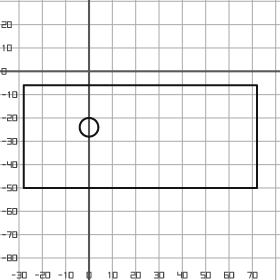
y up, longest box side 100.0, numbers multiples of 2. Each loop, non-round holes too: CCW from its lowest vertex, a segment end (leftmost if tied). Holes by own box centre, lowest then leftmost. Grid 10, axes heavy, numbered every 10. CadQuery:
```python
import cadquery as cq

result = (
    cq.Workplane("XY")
    .moveTo(-28.0, -50.0)
    .lineTo(72.0, -50.0)
    .lineTo(72.0, -6.0)
    .lineTo(-28.0, -6.0)
    .close()
    .moveTo(0.0, -24.0)
    .circle(4.0)
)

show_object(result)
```